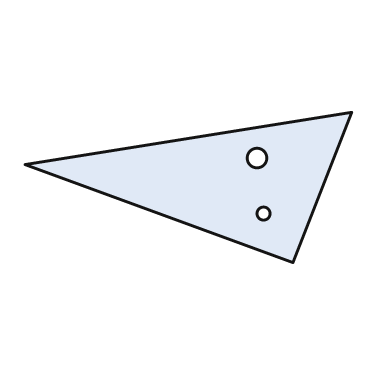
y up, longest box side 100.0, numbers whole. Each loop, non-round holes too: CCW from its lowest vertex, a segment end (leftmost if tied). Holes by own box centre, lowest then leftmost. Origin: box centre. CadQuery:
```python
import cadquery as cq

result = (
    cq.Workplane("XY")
    .moveTo(32.0, -23.0)
    .lineTo(50.0, 23.0)
    .lineTo(-50.0, 7.0)
    .close()
    .moveTo(23.0, -8.0)
    .circle(2.0)
    .moveTo(21.0, 9.0)
    .circle(3.0)
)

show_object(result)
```